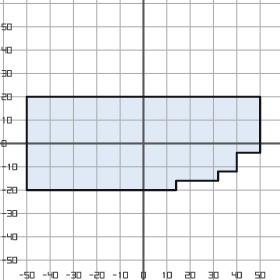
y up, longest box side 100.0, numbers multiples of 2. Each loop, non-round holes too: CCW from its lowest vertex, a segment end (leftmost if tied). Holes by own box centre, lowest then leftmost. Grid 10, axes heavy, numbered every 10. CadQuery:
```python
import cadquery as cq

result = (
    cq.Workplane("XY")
    .moveTo(-50.0, -20.0)
    .lineTo(14.0, -20.0)
    .lineTo(14.0, -16.0)
    .lineTo(32.0, -16.0)
    .lineTo(32.0, -12.0)
    .lineTo(40.0, -12.0)
    .lineTo(40.0, -4.0)
    .lineTo(50.0, -4.0)
    .lineTo(50.0, 20.0)
    .lineTo(-50.0, 20.0)
    .close()
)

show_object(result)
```